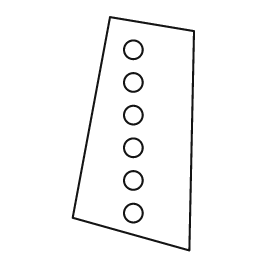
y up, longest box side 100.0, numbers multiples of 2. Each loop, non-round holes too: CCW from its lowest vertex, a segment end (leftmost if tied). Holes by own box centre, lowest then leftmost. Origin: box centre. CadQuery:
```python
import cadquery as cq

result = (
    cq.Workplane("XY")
    .moveTo(24.0, -50.0)
    .lineTo(26.0, 44.0)
    .lineTo(-10.0, 50.0)
    .lineTo(-26.0, -36.0)
    .close()
    .moveTo(0.0, -34.0)
    .circle(4.0)
    .moveTo(0.0, -20.0)
    .circle(4.0)
    .moveTo(0.0, -6.0)
    .circle(4.0)
    .moveTo(0.0, 8.0)
    .circle(4.0)
    .moveTo(0.0, 22.0)
    .circle(4.0)
    .moveTo(0.0, 36.0)
    .circle(4.0)
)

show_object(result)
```